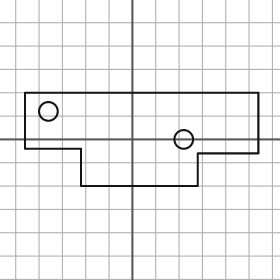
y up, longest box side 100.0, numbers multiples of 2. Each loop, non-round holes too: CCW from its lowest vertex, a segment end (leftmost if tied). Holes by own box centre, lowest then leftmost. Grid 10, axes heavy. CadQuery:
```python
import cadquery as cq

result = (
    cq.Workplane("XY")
    .moveTo(-22.0, -20.0)
    .lineTo(28.0, -20.0)
    .lineTo(28.0, -6.0)
    .lineTo(54.0, -6.0)
    .lineTo(54.0, 20.0)
    .lineTo(-46.0, 20.0)
    .lineTo(-46.0, -4.0)
    .lineTo(-22.0, -4.0)
    .close()
    .moveTo(22.0, 0.0)
    .circle(4.0)
    .moveTo(-36.0, 12.0)
    .circle(4.0)
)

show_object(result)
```